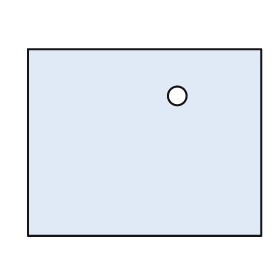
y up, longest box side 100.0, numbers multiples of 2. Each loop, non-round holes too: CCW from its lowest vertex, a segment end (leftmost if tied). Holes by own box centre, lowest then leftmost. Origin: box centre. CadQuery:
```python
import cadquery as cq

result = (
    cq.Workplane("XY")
    .moveTo(-50.0, -40.0)
    .lineTo(50.0, -40.0)
    .lineTo(50.0, 40.0)
    .lineTo(-50.0, 40.0)
    .close()
    .moveTo(14.0, 20.0)
    .circle(4.0)
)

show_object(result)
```